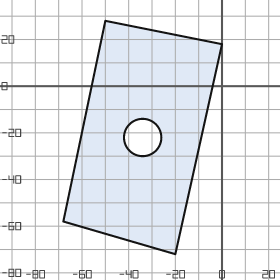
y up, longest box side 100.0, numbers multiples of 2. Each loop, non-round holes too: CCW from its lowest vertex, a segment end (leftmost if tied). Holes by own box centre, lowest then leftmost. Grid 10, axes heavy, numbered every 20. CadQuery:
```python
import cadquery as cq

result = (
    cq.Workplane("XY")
    .moveTo(-20.0, -72.0)
    .lineTo(0.0, 18.0)
    .lineTo(-50.0, 28.0)
    .lineTo(-68.0, -58.0)
    .close()
    .moveTo(-34.0, -22.0)
    .circle(8.0)
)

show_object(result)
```